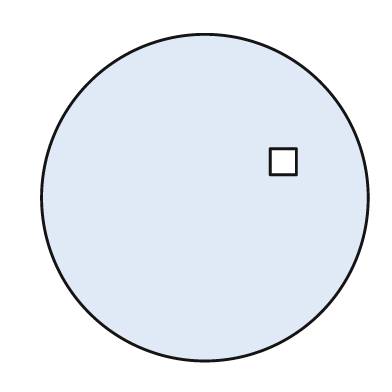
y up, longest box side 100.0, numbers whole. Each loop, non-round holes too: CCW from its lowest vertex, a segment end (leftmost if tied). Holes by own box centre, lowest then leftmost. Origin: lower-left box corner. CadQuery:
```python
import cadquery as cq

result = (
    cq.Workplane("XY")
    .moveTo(50.0, 50.0)
    .circle(50.0)
    .moveTo(70.0, 57.0)
    .lineTo(78.0, 57.0)
    .lineTo(78.0, 65.0)
    .lineTo(70.0, 65.0)
    .close()
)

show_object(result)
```